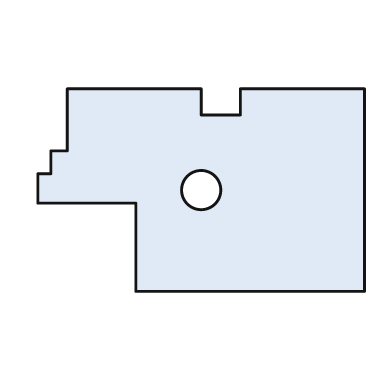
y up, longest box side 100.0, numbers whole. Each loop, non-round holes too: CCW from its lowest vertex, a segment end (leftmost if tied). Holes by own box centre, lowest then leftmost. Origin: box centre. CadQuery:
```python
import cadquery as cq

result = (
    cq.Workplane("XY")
    .moveTo(-20.0, -31.0)
    .lineTo(50.0, -31.0)
    .lineTo(50.0, 31.0)
    .lineTo(12.0, 31.0)
    .lineTo(12.0, 23.0)
    .lineTo(0.0, 23.0)
    .lineTo(0.0, 31.0)
    .lineTo(-41.0, 31.0)
    .lineTo(-41.0, 12.0)
    .lineTo(-46.0, 12.0)
    .lineTo(-46.0, 5.0)
    .lineTo(-50.0, 5.0)
    .lineTo(-50.0, -4.0)
    .lineTo(-20.0, -4.0)
    .close()
    .moveTo(0.0, 0.0)
    .circle(6.0)
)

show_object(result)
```